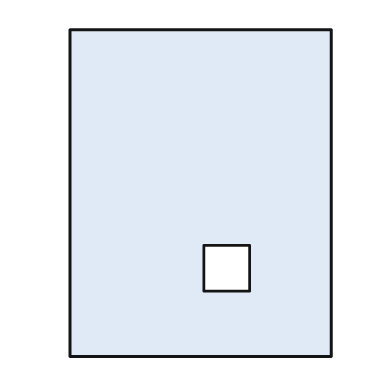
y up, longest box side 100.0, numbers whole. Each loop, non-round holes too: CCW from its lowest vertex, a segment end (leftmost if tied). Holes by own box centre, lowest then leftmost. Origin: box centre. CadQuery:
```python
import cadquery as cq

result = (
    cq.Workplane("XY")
    .moveTo(-40.0, -50.0)
    .lineTo(40.0, -50.0)
    .lineTo(40.0, 50.0)
    .lineTo(-40.0, 50.0)
    .close()
    .moveTo(1.0, -30.0)
    .lineTo(15.0, -30.0)
    .lineTo(15.0, -16.0)
    .lineTo(1.0, -16.0)
    .close()
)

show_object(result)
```